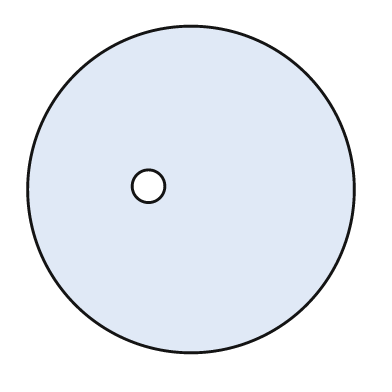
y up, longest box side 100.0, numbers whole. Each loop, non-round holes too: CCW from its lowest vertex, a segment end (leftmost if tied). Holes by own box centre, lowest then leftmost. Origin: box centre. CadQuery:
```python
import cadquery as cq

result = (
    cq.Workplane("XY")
    .moveTo(0.0, 0.0)
    .circle(50.0)
    .moveTo(-13.0, 1.0)
    .circle(5.0)
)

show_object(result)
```